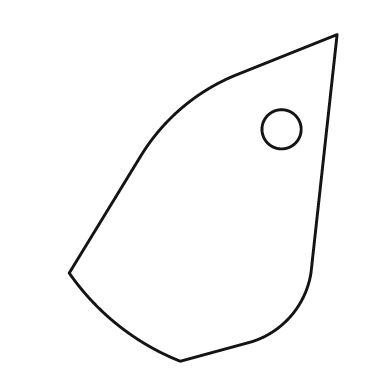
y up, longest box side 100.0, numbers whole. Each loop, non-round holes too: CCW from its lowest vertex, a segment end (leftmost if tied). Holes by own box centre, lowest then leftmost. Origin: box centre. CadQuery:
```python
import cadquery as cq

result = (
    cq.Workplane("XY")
    .moveTo(-7.0, -50.0)
    .lineTo(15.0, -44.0)
    .threePointArc((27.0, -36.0), (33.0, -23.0))
    .lineTo(41.0, 50.0)
    .lineTo(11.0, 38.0)
    .threePointArc((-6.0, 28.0), (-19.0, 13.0))
    .lineTo(-41.0, -23.0)
    .threePointArc((-26.0, -39.0), (-7.0, -50.0))
    .close()
    .moveTo(24.0, 21.0)
    .circle(6.0)
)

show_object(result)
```